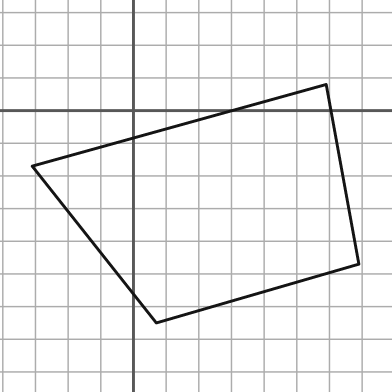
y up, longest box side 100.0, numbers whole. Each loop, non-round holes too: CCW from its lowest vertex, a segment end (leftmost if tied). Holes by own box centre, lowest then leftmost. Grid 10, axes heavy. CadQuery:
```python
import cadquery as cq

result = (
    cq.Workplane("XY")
    .moveTo(7.0, -65.0)
    .lineTo(69.0, -47.0)
    .lineTo(59.0, 8.0)
    .lineTo(-31.0, -17.0)
    .close()
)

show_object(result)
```